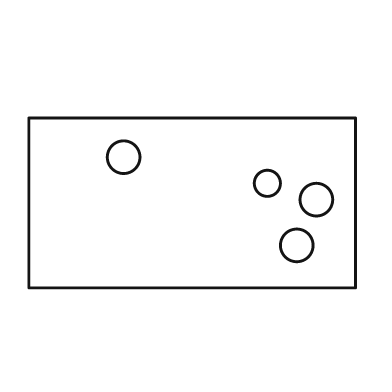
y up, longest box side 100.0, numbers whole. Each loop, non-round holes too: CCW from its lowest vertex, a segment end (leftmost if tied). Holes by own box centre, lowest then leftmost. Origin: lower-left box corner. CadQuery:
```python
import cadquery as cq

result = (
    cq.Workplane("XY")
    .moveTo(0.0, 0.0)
    .lineTo(100.0, 0.0)
    .lineTo(100.0, 52.0)
    .lineTo(0.0, 52.0)
    .close()
    .moveTo(82.0, 13.0)
    .circle(5.0)
    .moveTo(88.0, 27.0)
    .circle(5.0)
    .moveTo(73.0, 32.0)
    .circle(4.0)
    .moveTo(29.0, 40.0)
    .circle(5.0)
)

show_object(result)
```